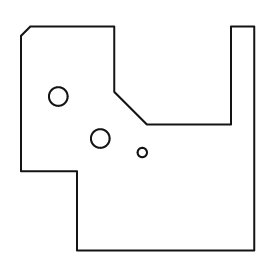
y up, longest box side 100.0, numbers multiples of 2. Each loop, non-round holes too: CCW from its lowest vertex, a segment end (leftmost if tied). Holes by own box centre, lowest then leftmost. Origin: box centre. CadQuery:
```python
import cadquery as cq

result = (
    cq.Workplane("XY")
    .moveTo(-26.0, -48.0)
    .lineTo(50.0, -48.0)
    .lineTo(50.0, 48.0)
    .lineTo(40.0, 48.0)
    .lineTo(40.0, 6.0)
    .lineTo(4.0, 6.0)
    .lineTo(-10.0, 20.0)
    .lineTo(-10.0, 48.0)
    .lineTo(-46.0, 48.0)
    .lineTo(-50.0, 44.0)
    .lineTo(-50.0, -14.0)
    .lineTo(-26.0, -14.0)
    .close()
    .moveTo(2.0, -6.0)
    .circle(2.0)
    .moveTo(-16.0, 0.0)
    .circle(4.0)
    .moveTo(-34.0, 18.0)
    .circle(4.0)
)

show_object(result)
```